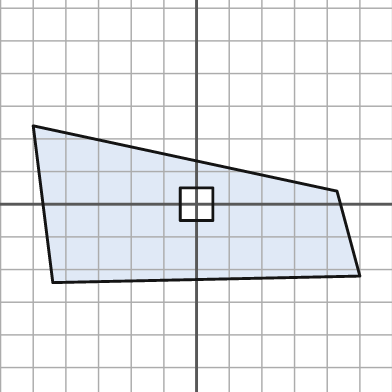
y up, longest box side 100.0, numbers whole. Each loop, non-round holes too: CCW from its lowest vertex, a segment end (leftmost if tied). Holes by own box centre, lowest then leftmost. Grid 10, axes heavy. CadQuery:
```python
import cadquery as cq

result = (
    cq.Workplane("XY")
    .moveTo(-44.0, -24.0)
    .lineTo(50.0, -22.0)
    .lineTo(43.0, 4.0)
    .lineTo(-50.0, 24.0)
    .close()
    .moveTo(-5.0, -5.0)
    .lineTo(5.0, -5.0)
    .lineTo(5.0, 5.0)
    .lineTo(-5.0, 5.0)
    .close()
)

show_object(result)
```